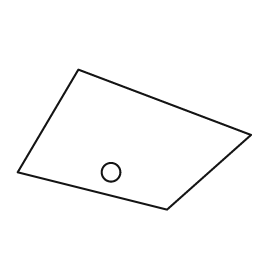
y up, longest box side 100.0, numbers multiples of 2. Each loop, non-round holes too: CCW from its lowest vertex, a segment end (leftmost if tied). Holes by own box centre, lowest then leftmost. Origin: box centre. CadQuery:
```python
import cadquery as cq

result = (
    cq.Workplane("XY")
    .moveTo(14.0, -30.0)
    .lineTo(50.0, 2.0)
    .lineTo(-24.0, 30.0)
    .lineTo(-50.0, -14.0)
    .close()
    .moveTo(-10.0, -14.0)
    .circle(4.0)
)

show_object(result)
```